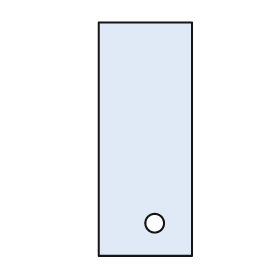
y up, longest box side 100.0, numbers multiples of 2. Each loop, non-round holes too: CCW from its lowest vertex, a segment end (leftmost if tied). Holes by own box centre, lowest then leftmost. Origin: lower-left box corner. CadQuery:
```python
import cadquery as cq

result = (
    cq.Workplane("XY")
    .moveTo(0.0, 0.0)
    .lineTo(40.0, 0.0)
    .lineTo(40.0, 100.0)
    .lineTo(0.0, 100.0)
    .close()
    .moveTo(24.0, 14.0)
    .circle(4.0)
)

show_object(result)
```